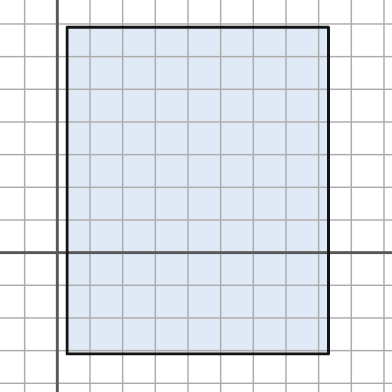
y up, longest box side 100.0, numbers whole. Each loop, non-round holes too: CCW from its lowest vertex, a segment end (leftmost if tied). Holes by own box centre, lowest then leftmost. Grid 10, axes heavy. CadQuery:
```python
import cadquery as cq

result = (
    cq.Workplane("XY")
    .moveTo(3.0, -31.0)
    .lineTo(83.0, -31.0)
    .lineTo(83.0, 69.0)
    .lineTo(3.0, 69.0)
    .close()
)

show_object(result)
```